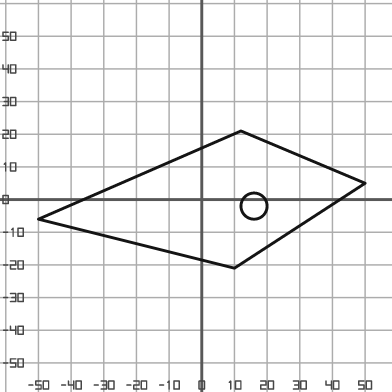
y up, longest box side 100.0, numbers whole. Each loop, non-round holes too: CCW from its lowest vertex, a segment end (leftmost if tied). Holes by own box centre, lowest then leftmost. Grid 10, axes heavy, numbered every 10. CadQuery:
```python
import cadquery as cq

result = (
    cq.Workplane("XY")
    .moveTo(10.0, -21.0)
    .lineTo(50.0, 5.0)
    .lineTo(12.0, 21.0)
    .lineTo(-50.0, -6.0)
    .close()
    .moveTo(16.0, -2.0)
    .circle(4.0)
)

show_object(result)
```